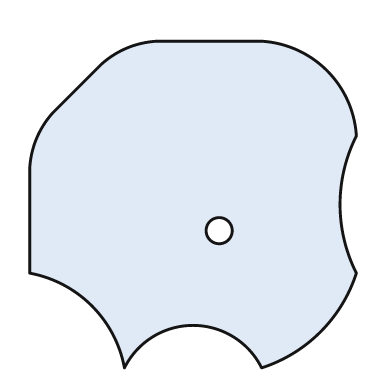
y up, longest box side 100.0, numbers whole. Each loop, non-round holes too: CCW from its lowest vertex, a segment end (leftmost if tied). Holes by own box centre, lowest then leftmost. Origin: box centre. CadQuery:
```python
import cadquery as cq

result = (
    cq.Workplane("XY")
    .moveTo(-21.0, -50.0)
    .threePointArc((0.0, -37.0), (21.0, -50.0))
    .threePointArc((39.0, -39.0), (50.0, -21.0))
    .threePointArc((45.0, 0.0), (50.0, 21.0))
    .threePointArc((41.0, 41.0), (21.0, 50.0))
    .lineTo(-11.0, 50.0)
    .threePointArc((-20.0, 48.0), (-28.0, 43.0))
    .lineTo(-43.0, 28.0)
    .threePointArc((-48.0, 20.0), (-50.0, 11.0))
    .lineTo(-50.0, -21.0)
    .threePointArc((-31.0, -31.0), (-21.0, -50.0))
    .close()
    .moveTo(8.0, -8.0)
    .circle(4.0)
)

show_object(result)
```